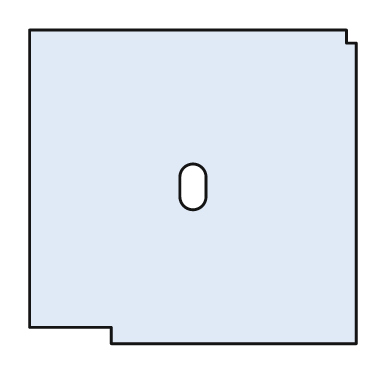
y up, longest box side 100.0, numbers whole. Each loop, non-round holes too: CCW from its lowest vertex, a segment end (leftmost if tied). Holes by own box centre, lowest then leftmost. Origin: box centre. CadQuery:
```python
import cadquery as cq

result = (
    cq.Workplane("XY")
    .moveTo(-25.0, -48.0)
    .lineTo(50.0, -48.0)
    .lineTo(50.0, 44.0)
    .lineTo(47.0, 44.0)
    .lineTo(47.0, 48.0)
    .lineTo(-50.0, 48.0)
    .lineTo(-50.0, -43.0)
    .lineTo(-25.0, -43.0)
    .close()
    .moveTo(-4.0, -3.0)
    .threePointArc((0.0, -7.0), (4.0, -3.0))
    .lineTo(4.0, 3.0)
    .threePointArc((0.0, 7.0), (-4.0, 3.0))
    .close()
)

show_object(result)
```